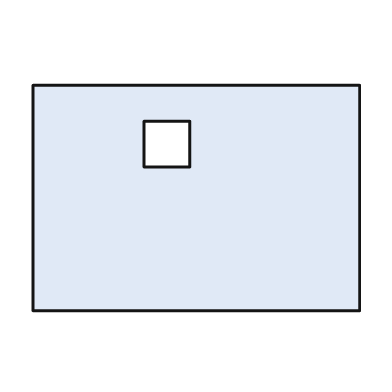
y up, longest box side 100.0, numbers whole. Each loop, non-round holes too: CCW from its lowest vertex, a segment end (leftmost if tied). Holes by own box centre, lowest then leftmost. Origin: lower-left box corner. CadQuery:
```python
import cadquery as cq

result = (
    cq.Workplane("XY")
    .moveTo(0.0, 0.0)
    .lineTo(100.0, 0.0)
    .lineTo(100.0, 69.0)
    .lineTo(0.0, 69.0)
    .close()
    .moveTo(34.0, 44.0)
    .lineTo(48.0, 44.0)
    .lineTo(48.0, 58.0)
    .lineTo(34.0, 58.0)
    .close()
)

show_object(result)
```